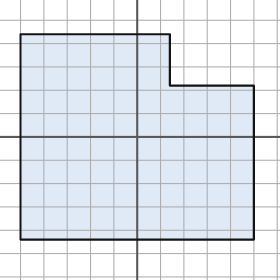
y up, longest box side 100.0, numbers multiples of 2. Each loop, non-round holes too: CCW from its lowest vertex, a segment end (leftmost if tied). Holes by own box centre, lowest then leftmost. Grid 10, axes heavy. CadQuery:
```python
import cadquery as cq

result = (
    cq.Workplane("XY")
    .moveTo(-50.0, -44.0)
    .lineTo(50.0, -44.0)
    .lineTo(50.0, 22.0)
    .lineTo(14.0, 22.0)
    .lineTo(14.0, 44.0)
    .lineTo(-50.0, 44.0)
    .close()
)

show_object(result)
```